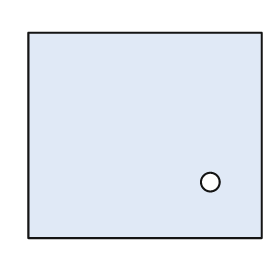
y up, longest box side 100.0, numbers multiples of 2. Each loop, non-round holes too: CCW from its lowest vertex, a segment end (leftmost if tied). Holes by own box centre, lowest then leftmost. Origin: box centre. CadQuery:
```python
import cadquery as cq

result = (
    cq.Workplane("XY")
    .moveTo(-50.0, -44.0)
    .lineTo(50.0, -44.0)
    .lineTo(50.0, 44.0)
    .lineTo(-50.0, 44.0)
    .close()
    .moveTo(28.0, -20.0)
    .circle(4.0)
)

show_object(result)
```